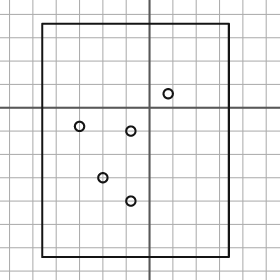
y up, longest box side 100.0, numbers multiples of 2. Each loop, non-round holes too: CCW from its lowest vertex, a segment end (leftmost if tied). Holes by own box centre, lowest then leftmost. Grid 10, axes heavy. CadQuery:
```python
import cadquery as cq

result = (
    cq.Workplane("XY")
    .moveTo(-46.0, -64.0)
    .lineTo(34.0, -64.0)
    .lineTo(34.0, 36.0)
    .lineTo(-46.0, 36.0)
    .close()
    .moveTo(-8.0, -40.0)
    .circle(2.0)
    .moveTo(-20.0, -30.0)
    .circle(2.0)
    .moveTo(-8.0, -10.0)
    .circle(2.0)
    .moveTo(-30.0, -8.0)
    .circle(2.0)
    .moveTo(8.0, 6.0)
    .circle(2.0)
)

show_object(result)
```